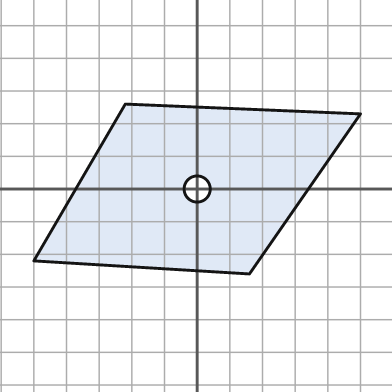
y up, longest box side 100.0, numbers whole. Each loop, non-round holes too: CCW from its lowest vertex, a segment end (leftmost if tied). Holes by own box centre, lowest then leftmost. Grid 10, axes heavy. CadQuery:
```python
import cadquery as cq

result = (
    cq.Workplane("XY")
    .moveTo(16.0, -26.0)
    .lineTo(50.0, 23.0)
    .lineTo(-22.0, 26.0)
    .lineTo(-50.0, -22.0)
    .close()
    .moveTo(0.0, 0.0)
    .circle(4.0)
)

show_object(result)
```